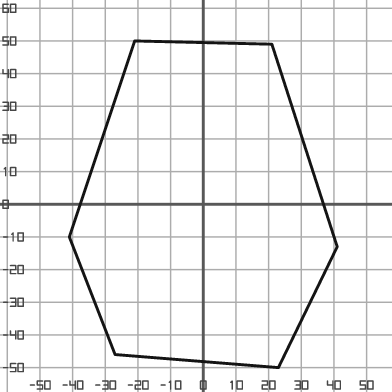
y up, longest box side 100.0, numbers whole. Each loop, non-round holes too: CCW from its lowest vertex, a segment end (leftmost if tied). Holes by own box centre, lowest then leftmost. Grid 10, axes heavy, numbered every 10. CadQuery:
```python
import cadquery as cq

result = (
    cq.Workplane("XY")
    .moveTo(23.0, -50.0)
    .lineTo(41.0, -13.0)
    .lineTo(21.0, 49.0)
    .lineTo(-21.0, 50.0)
    .lineTo(-41.0, -10.0)
    .lineTo(-27.0, -46.0)
    .close()
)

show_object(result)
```